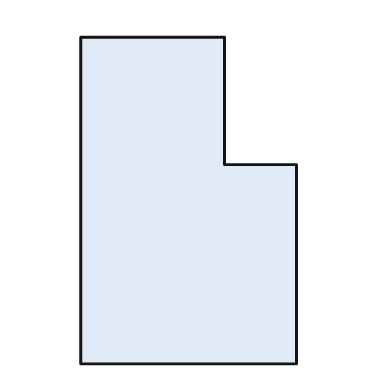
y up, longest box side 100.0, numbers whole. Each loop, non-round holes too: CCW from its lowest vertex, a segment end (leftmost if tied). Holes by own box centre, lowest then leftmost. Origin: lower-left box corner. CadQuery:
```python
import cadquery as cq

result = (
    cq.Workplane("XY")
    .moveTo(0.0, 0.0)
    .lineTo(66.0, 0.0)
    .lineTo(66.0, 61.0)
    .lineTo(44.0, 61.0)
    .lineTo(44.0, 100.0)
    .lineTo(0.0, 100.0)
    .close()
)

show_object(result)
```